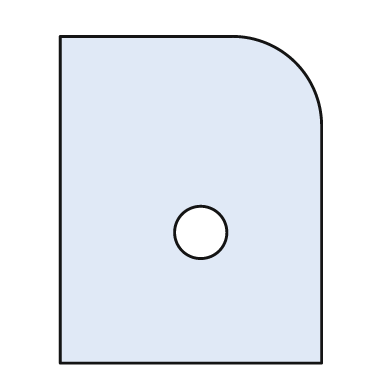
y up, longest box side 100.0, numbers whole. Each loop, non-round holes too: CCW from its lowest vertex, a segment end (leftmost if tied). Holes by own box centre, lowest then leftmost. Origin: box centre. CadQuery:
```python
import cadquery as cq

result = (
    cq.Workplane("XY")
    .moveTo(-40.0, -50.0)
    .lineTo(40.0, -50.0)
    .lineTo(40.0, 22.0)
    .threePointArc((32.0, 42.0), (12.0, 50.0))
    .lineTo(-40.0, 50.0)
    .close()
    .moveTo(3.0, -10.0)
    .circle(8.0)
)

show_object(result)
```